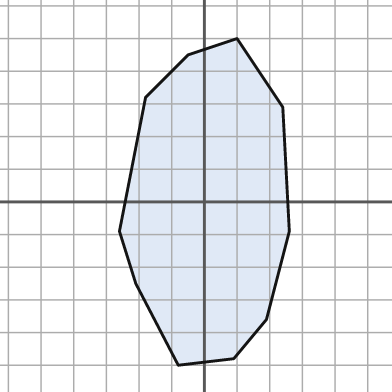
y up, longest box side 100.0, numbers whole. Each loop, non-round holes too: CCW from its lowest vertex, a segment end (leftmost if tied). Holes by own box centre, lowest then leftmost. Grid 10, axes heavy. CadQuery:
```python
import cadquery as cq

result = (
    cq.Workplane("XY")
    .moveTo(-8.0, -50.0)
    .lineTo(9.0, -48.0)
    .lineTo(19.0, -36.0)
    .lineTo(26.0, -9.0)
    .lineTo(24.0, 29.0)
    .lineTo(10.0, 50.0)
    .lineTo(-5.0, 45.0)
    .lineTo(-18.0, 32.0)
    .lineTo(-26.0, -9.0)
    .lineTo(-21.0, -25.0)
    .close()
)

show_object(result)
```